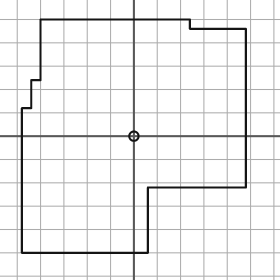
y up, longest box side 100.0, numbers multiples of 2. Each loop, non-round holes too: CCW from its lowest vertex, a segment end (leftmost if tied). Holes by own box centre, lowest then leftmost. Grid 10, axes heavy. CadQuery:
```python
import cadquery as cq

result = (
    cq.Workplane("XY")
    .moveTo(-48.0, -50.0)
    .lineTo(6.0, -50.0)
    .lineTo(6.0, -22.0)
    .lineTo(48.0, -22.0)
    .lineTo(48.0, 46.0)
    .lineTo(24.0, 46.0)
    .lineTo(24.0, 50.0)
    .lineTo(-40.0, 50.0)
    .lineTo(-40.0, 24.0)
    .lineTo(-44.0, 24.0)
    .lineTo(-44.0, 12.0)
    .lineTo(-48.0, 12.0)
    .close()
    .moveTo(0.0, 0.0)
    .circle(2.0)
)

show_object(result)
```